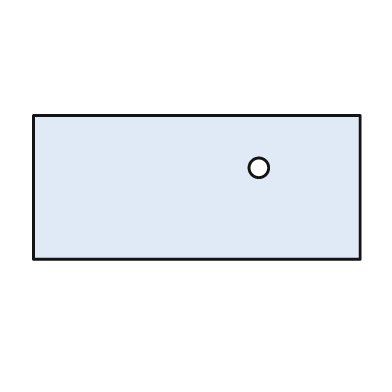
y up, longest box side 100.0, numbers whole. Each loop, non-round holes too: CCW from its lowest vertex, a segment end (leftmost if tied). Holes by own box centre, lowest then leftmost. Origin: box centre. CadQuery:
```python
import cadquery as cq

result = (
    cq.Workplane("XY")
    .moveTo(-50.0, -22.0)
    .lineTo(50.0, -22.0)
    .lineTo(50.0, 22.0)
    .lineTo(-50.0, 22.0)
    .close()
    .moveTo(19.0, 6.0)
    .circle(3.0)
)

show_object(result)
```